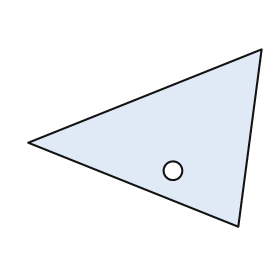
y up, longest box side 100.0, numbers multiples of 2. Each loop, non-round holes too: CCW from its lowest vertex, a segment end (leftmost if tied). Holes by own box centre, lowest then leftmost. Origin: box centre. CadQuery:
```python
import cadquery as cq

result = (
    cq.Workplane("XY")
    .moveTo(40.0, -38.0)
    .lineTo(50.0, 38.0)
    .lineTo(-50.0, -2.0)
    .close()
    .moveTo(12.0, -14.0)
    .circle(4.0)
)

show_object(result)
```